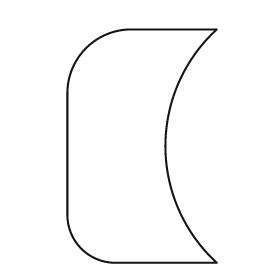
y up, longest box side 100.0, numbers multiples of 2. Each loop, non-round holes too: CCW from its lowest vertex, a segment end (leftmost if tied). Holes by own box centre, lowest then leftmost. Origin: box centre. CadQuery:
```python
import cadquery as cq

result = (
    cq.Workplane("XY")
    .moveTo(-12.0, -50.0)
    .lineTo(32.0, -50.0)
    .threePointArc((10.0, 0.0), (32.0, 50.0))
    .lineTo(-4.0, 50.0)
    .threePointArc((-24.0, 42.0), (-32.0, 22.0))
    .lineTo(-32.0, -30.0)
    .threePointArc((-26.0, -44.0), (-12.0, -50.0))
    .close()
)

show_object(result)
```